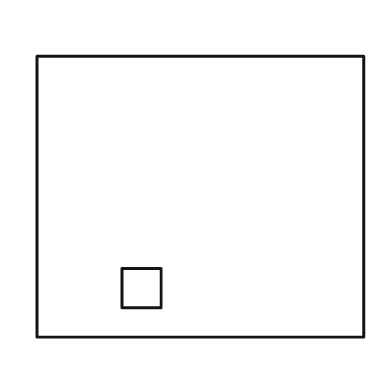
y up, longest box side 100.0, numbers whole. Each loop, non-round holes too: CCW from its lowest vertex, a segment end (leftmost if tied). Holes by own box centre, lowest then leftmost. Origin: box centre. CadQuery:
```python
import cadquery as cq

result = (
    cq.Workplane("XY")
    .moveTo(-50.0, -43.0)
    .lineTo(50.0, -43.0)
    .lineTo(50.0, 43.0)
    .lineTo(-50.0, 43.0)
    .close()
    .moveTo(-24.0, -34.0)
    .lineTo(-12.0, -34.0)
    .lineTo(-12.0, -22.0)
    .lineTo(-24.0, -22.0)
    .close()
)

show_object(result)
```